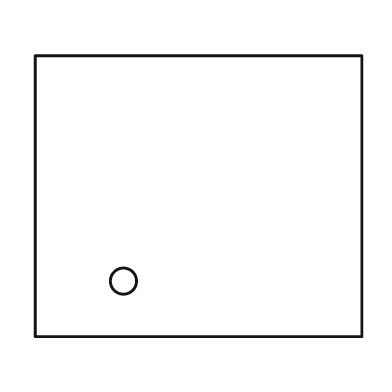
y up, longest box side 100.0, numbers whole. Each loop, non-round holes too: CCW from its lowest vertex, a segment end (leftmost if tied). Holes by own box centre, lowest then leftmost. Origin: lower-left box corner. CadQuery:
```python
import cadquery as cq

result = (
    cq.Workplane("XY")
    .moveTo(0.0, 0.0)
    .lineTo(100.0, 0.0)
    .lineTo(100.0, 86.0)
    .lineTo(0.0, 86.0)
    .close()
    .moveTo(27.0, 17.0)
    .circle(4.0)
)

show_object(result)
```